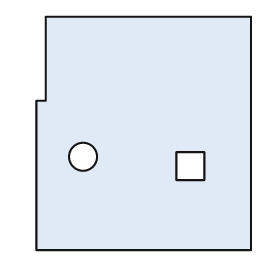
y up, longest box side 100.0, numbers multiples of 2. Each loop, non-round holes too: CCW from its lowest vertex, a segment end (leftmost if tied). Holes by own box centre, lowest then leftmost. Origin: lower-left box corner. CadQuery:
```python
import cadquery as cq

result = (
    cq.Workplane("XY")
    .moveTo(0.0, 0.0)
    .lineTo(92.0, 0.0)
    .lineTo(92.0, 100.0)
    .lineTo(4.0, 100.0)
    .lineTo(4.0, 64.0)
    .lineTo(0.0, 64.0)
    .close()
    .moveTo(60.0, 30.0)
    .lineTo(72.0, 30.0)
    .lineTo(72.0, 42.0)
    .lineTo(60.0, 42.0)
    .close()
    .moveTo(20.0, 40.0)
    .circle(6.0)
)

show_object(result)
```